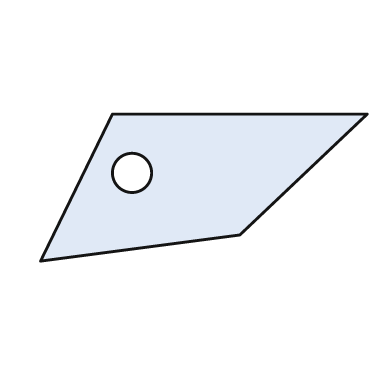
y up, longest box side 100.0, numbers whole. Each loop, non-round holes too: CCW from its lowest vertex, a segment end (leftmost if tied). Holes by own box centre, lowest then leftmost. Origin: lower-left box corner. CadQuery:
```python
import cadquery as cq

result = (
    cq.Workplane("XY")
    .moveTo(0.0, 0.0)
    .lineTo(61.0, 8.0)
    .lineTo(100.0, 45.0)
    .lineTo(22.0, 45.0)
    .close()
    .moveTo(28.0, 27.0)
    .circle(6.0)
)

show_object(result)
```